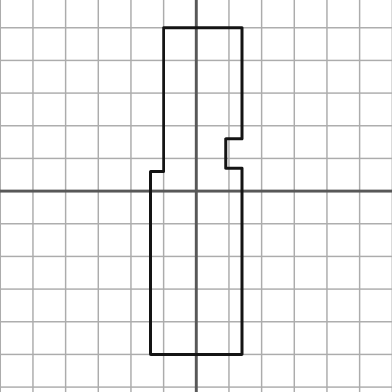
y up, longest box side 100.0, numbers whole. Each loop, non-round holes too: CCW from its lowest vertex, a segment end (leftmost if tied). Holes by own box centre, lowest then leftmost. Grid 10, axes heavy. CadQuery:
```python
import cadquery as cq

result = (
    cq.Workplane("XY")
    .moveTo(-14.0, -50.0)
    .lineTo(14.0, -50.0)
    .lineTo(14.0, 7.0)
    .lineTo(9.0, 7.0)
    .lineTo(9.0, 16.0)
    .lineTo(14.0, 16.0)
    .lineTo(14.0, 50.0)
    .lineTo(-10.0, 50.0)
    .lineTo(-10.0, 6.0)
    .lineTo(-14.0, 6.0)
    .close()
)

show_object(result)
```